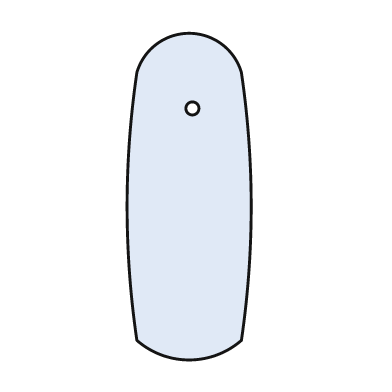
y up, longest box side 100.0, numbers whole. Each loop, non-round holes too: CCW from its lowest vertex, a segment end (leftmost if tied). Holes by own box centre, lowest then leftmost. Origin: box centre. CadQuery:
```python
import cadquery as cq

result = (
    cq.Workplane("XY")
    .moveTo(-16.0, -44.0)
    .threePointArc((0.0, -50.0), (16.0, -44.0))
    .threePointArc((19.0, -3.0), (16.0, 38.0))
    .threePointArc((0.0, 50.0), (-16.0, 38.0))
    .threePointArc((-19.0, -3.0), (-16.0, -44.0))
    .close()
    .moveTo(1.0, 27.0)
    .circle(2.0)
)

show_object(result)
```